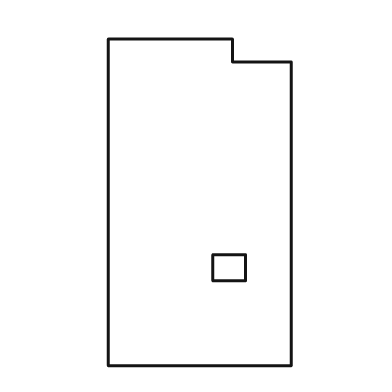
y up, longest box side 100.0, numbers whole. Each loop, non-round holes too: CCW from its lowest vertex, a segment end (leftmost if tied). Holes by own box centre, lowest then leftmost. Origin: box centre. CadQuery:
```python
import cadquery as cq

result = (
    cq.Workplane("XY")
    .moveTo(-28.0, -50.0)
    .lineTo(28.0, -50.0)
    .lineTo(28.0, 43.0)
    .lineTo(10.0, 43.0)
    .lineTo(10.0, 50.0)
    .lineTo(-28.0, 50.0)
    .close()
    .moveTo(4.0, -24.0)
    .lineTo(14.0, -24.0)
    .lineTo(14.0, -16.0)
    .lineTo(4.0, -16.0)
    .close()
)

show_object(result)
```